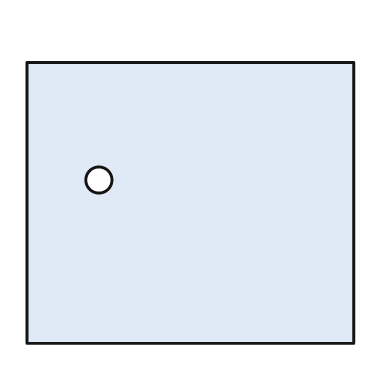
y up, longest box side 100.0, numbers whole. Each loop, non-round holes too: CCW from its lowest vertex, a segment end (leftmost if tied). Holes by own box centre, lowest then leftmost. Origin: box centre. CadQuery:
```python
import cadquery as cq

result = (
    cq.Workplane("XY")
    .moveTo(-50.0, -43.0)
    .lineTo(50.0, -43.0)
    .lineTo(50.0, 43.0)
    .lineTo(-50.0, 43.0)
    .close()
    .moveTo(-28.0, 7.0)
    .circle(4.0)
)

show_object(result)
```